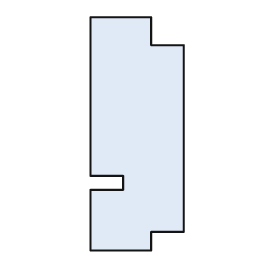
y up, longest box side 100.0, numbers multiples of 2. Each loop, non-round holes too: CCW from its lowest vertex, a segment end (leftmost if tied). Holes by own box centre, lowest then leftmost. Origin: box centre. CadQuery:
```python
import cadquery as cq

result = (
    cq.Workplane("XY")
    .moveTo(-20.0, -50.0)
    .lineTo(6.0, -50.0)
    .lineTo(6.0, -42.0)
    .lineTo(20.0, -42.0)
    .lineTo(20.0, 38.0)
    .lineTo(6.0, 38.0)
    .lineTo(6.0, 50.0)
    .lineTo(-20.0, 50.0)
    .lineTo(-20.0, -18.0)
    .lineTo(-6.0, -18.0)
    .lineTo(-6.0, -24.0)
    .lineTo(-20.0, -24.0)
    .close()
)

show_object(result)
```